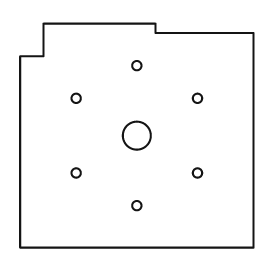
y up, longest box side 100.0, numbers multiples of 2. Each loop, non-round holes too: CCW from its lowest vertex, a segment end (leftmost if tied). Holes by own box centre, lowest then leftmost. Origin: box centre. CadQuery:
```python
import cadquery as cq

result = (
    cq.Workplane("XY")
    .moveTo(-50.0, -48.0)
    .lineTo(50.0, -48.0)
    .lineTo(50.0, 44.0)
    .lineTo(8.0, 44.0)
    .lineTo(8.0, 48.0)
    .lineTo(-40.0, 48.0)
    .lineTo(-40.0, 34.0)
    .lineTo(-50.0, 34.0)
    .close()
    .moveTo(0.0, -30.0)
    .circle(2.0)
    .moveTo(-26.0, -16.0)
    .circle(2.0)
    .moveTo(26.0, -16.0)
    .circle(2.0)
    .moveTo(0.0, 0.0)
    .circle(6.0)
    .moveTo(-26.0, 16.0)
    .circle(2.0)
    .moveTo(26.0, 16.0)
    .circle(2.0)
    .moveTo(0.0, 30.0)
    .circle(2.0)
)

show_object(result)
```